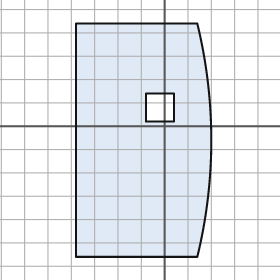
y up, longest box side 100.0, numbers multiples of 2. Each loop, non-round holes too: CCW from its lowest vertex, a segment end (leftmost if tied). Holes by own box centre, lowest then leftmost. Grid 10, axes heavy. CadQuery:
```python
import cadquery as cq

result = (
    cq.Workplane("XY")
    .moveTo(-38.0, -56.0)
    .lineTo(14.0, -56.0)
    .threePointArc((20.0, -6.0), (14.0, 44.0))
    .lineTo(-38.0, 44.0)
    .close()
    .moveTo(-8.0, 2.0)
    .lineTo(4.0, 2.0)
    .lineTo(4.0, 14.0)
    .lineTo(-8.0, 14.0)
    .close()
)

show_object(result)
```